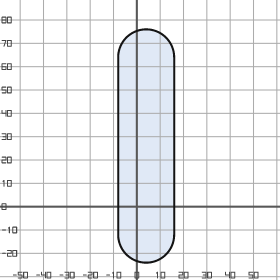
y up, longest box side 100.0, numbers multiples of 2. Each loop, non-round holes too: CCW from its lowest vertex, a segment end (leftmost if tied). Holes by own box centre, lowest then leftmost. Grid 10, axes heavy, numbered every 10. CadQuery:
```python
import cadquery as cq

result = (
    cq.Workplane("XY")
    .moveTo(-8.0, -12.0)
    .threePointArc((4.0, -24.0), (16.0, -12.0))
    .lineTo(16.0, 64.0)
    .threePointArc((4.0, 76.0), (-8.0, 64.0))
    .close()
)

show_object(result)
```